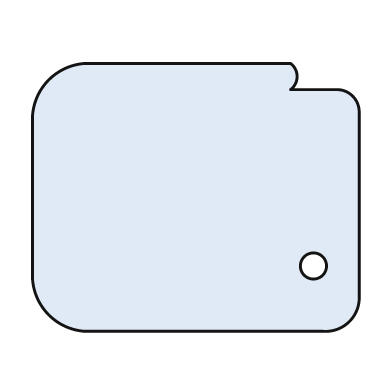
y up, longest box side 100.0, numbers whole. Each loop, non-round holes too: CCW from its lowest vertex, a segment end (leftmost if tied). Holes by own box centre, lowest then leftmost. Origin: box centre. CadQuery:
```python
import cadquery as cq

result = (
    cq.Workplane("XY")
    .moveTo(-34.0, -41.0)
    .lineTo(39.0, -41.0)
    .threePointArc((47.0, -38.0), (50.0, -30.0))
    .lineTo(50.0, 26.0)
    .threePointArc((48.0, 31.0), (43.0, 33.0))
    .lineTo(29.0, 33.0)
    .threePointArc((31.0, 37.0), (29.0, 41.0))
    .lineTo(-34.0, 41.0)
    .threePointArc((-45.0, 36.0), (-50.0, 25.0))
    .lineTo(-50.0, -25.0)
    .threePointArc((-45.0, -36.0), (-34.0, -41.0))
    .close()
    .moveTo(36.0, -21.0)
    .circle(4.0)
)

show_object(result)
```